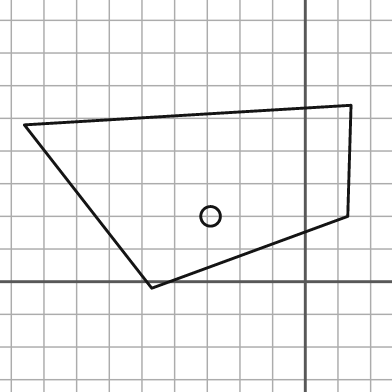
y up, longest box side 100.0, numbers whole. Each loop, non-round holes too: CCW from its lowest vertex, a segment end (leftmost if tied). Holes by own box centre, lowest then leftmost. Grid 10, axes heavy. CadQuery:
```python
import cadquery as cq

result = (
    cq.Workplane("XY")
    .moveTo(-47.0, -2.0)
    .lineTo(13.0, 20.0)
    .lineTo(14.0, 54.0)
    .lineTo(-86.0, 48.0)
    .close()
    .moveTo(-29.0, 20.0)
    .circle(3.0)
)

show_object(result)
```